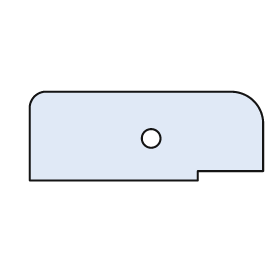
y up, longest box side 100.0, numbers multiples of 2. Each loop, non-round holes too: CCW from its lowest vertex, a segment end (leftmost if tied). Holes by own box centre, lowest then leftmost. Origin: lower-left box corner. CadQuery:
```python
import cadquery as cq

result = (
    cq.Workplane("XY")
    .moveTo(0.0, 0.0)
    .lineTo(72.0, 0.0)
    .lineTo(72.0, 4.0)
    .lineTo(100.0, 4.0)
    .lineTo(100.0, 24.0)
    .threePointArc((96.0, 34.0), (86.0, 38.0))
    .lineTo(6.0, 38.0)
    .threePointArc((2.0, 36.0), (0.0, 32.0))
    .close()
    .moveTo(52.0, 18.0)
    .circle(4.0)
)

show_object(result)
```